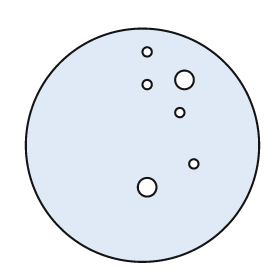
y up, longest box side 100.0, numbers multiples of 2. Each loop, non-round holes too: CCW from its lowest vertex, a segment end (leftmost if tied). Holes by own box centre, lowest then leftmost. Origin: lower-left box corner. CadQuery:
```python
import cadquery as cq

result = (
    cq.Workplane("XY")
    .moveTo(50.0, 50.0)
    .circle(50.0)
    .moveTo(52.0, 32.0)
    .circle(4.0)
    .moveTo(72.0, 42.0)
    .circle(2.0)
    .moveTo(66.0, 64.0)
    .circle(2.0)
    .moveTo(52.0, 76.0)
    .circle(2.0)
    .moveTo(68.0, 78.0)
    .circle(4.0)
    .moveTo(52.0, 90.0)
    .circle(2.0)
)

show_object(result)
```